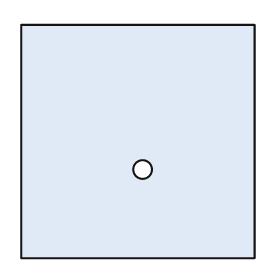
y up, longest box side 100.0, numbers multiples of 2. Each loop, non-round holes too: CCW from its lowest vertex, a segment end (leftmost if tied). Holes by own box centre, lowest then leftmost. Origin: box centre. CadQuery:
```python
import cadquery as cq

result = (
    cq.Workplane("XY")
    .moveTo(-50.0, -50.0)
    .lineTo(50.0, -50.0)
    .lineTo(50.0, 50.0)
    .lineTo(-50.0, 50.0)
    .close()
    .moveTo(2.0, -12.0)
    .circle(4.0)
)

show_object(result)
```